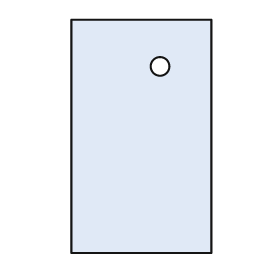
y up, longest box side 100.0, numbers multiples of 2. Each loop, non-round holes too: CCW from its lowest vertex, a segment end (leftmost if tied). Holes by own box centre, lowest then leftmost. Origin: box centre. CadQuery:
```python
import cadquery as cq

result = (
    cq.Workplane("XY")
    .moveTo(-30.0, -50.0)
    .lineTo(30.0, -50.0)
    .lineTo(30.0, 50.0)
    .lineTo(-30.0, 50.0)
    .close()
    .moveTo(8.0, 30.0)
    .circle(4.0)
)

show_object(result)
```